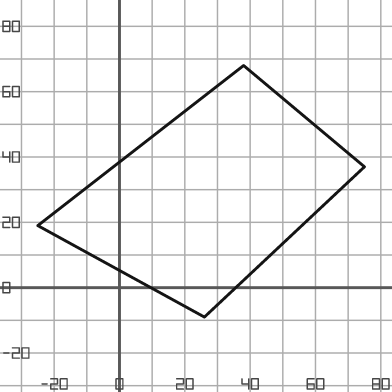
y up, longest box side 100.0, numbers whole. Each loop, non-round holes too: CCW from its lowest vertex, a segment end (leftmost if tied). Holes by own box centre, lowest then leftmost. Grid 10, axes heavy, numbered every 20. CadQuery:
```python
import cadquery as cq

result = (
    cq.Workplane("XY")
    .moveTo(26.0, -9.0)
    .lineTo(75.0, 37.0)
    .lineTo(38.0, 68.0)
    .lineTo(-25.0, 19.0)
    .close()
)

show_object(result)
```